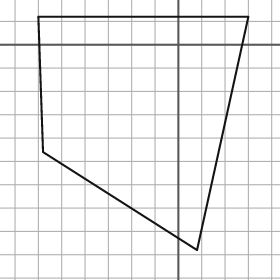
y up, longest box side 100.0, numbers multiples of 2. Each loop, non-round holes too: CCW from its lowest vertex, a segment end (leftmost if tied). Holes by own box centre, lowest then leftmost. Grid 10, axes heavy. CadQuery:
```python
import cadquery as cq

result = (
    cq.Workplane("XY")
    .moveTo(8.0, -88.0)
    .lineTo(30.0, 12.0)
    .lineTo(-60.0, 12.0)
    .lineTo(-58.0, -46.0)
    .close()
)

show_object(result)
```